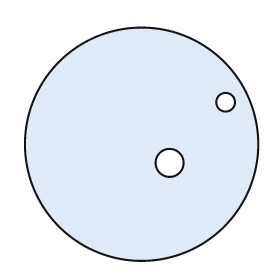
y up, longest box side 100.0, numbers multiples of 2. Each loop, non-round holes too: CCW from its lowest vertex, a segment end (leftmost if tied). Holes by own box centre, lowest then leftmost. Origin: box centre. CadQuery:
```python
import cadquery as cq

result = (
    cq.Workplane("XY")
    .moveTo(0.0, 0.0)
    .circle(50.0)
    .moveTo(12.0, -8.0)
    .circle(6.0)
    .moveTo(36.0, 18.0)
    .circle(4.0)
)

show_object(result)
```